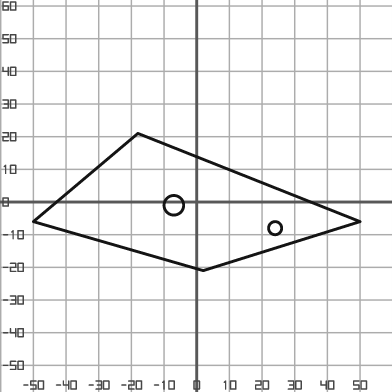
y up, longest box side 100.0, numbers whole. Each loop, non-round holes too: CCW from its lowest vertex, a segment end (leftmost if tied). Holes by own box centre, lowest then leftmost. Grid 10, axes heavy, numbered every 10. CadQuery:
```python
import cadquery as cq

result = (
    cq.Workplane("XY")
    .moveTo(2.0, -21.0)
    .lineTo(50.0, -6.0)
    .lineTo(-18.0, 21.0)
    .lineTo(-50.0, -6.0)
    .close()
    .moveTo(24.0, -8.0)
    .circle(2.0)
    .moveTo(-7.0, -1.0)
    .circle(3.0)
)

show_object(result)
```